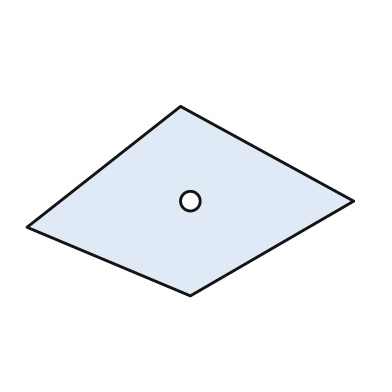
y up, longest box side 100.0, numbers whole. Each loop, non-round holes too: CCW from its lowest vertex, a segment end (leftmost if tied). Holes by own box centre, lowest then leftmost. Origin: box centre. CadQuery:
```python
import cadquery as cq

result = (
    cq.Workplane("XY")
    .moveTo(0.0, -29.0)
    .lineTo(50.0, 0.0)
    .lineTo(-3.0, 29.0)
    .lineTo(-50.0, -8.0)
    .close()
    .moveTo(0.0, 0.0)
    .circle(3.0)
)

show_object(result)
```